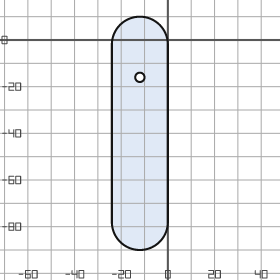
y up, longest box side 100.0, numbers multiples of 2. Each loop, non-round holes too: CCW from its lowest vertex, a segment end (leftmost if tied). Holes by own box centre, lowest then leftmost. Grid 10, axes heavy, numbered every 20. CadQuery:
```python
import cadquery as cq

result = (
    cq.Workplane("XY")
    .moveTo(-24.0, -78.0)
    .threePointArc((-12.0, -90.0), (0.0, -78.0))
    .lineTo(0.0, -2.0)
    .threePointArc((-12.0, 10.0), (-24.0, -2.0))
    .close()
    .moveTo(-12.0, -16.0)
    .circle(2.0)
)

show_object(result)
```